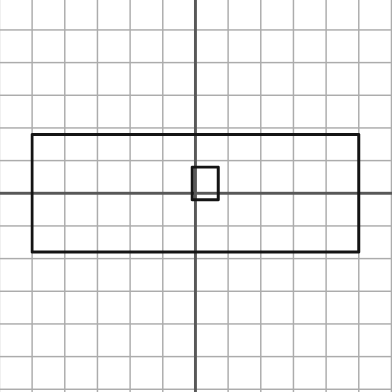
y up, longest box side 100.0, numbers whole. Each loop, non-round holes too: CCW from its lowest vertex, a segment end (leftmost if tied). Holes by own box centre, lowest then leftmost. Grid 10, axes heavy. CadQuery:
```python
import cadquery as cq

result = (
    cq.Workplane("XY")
    .moveTo(-50.0, -18.0)
    .lineTo(50.0, -18.0)
    .lineTo(50.0, 18.0)
    .lineTo(-50.0, 18.0)
    .close()
    .moveTo(-1.0, -2.0)
    .lineTo(7.0, -2.0)
    .lineTo(7.0, 8.0)
    .lineTo(-1.0, 8.0)
    .close()
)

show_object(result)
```